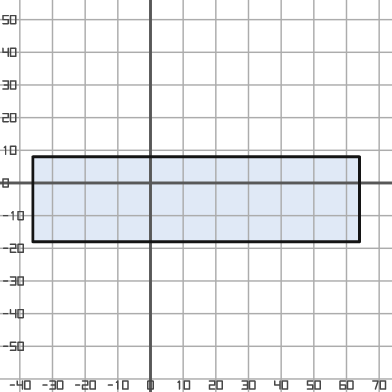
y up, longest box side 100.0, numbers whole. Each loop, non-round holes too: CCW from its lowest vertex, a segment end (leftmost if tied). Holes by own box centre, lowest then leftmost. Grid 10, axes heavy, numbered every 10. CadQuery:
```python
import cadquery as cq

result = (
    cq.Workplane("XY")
    .moveTo(-36.0, -18.0)
    .lineTo(64.0, -18.0)
    .lineTo(64.0, 8.0)
    .lineTo(-36.0, 8.0)
    .close()
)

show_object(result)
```